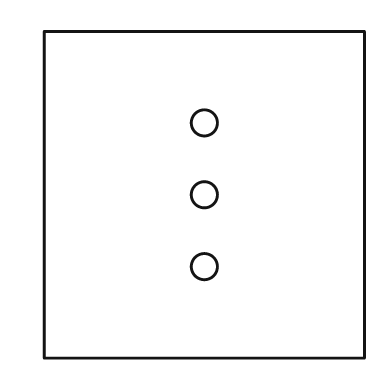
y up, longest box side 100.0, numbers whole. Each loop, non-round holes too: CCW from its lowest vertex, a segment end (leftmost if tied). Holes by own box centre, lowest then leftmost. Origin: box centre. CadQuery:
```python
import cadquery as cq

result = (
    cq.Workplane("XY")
    .moveTo(-49.0, -50.0)
    .lineTo(49.0, -50.0)
    .lineTo(49.0, 50.0)
    .lineTo(-49.0, 50.0)
    .close()
    .moveTo(0.0, -22.0)
    .circle(4.0)
    .moveTo(0.0, 0.0)
    .circle(4.0)
    .moveTo(0.0, 22.0)
    .circle(4.0)
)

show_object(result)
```